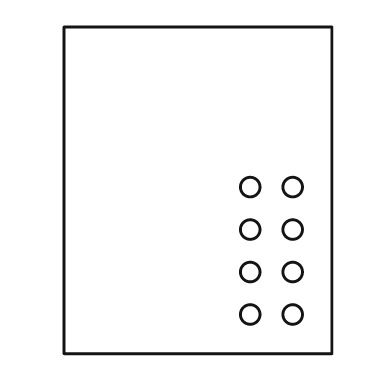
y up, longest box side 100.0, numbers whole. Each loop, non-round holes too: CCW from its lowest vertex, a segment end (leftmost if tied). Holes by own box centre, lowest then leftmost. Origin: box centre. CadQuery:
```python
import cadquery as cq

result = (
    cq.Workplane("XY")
    .moveTo(-41.0, -50.0)
    .lineTo(41.0, -50.0)
    .lineTo(41.0, 50.0)
    .lineTo(-41.0, 50.0)
    .close()
    .moveTo(16.0, -38.0)
    .circle(3.0)
    .moveTo(29.0, -38.0)
    .circle(3.0)
    .moveTo(16.0, -25.0)
    .circle(3.0)
    .moveTo(29.0, -25.0)
    .circle(3.0)
    .moveTo(16.0, -12.0)
    .circle(3.0)
    .moveTo(29.0, -12.0)
    .circle(3.0)
    .moveTo(16.0, 1.0)
    .circle(3.0)
    .moveTo(29.0, 1.0)
    .circle(3.0)
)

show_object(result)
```